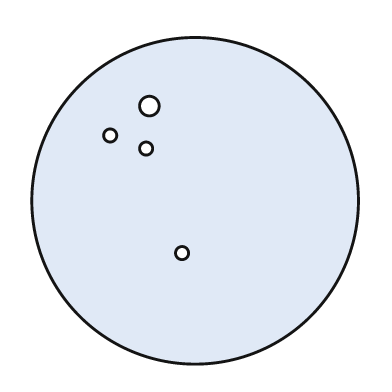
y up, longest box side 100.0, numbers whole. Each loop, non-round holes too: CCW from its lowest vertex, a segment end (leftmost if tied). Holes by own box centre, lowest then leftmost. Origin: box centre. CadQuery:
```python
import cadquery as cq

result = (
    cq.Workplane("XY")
    .moveTo(0.0, 0.0)
    .circle(50.0)
    .moveTo(-4.0, -16.0)
    .circle(2.0)
    .moveTo(-15.0, 16.0)
    .circle(2.0)
    .moveTo(-26.0, 20.0)
    .circle(2.0)
    .moveTo(-14.0, 29.0)
    .circle(3.0)
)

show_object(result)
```